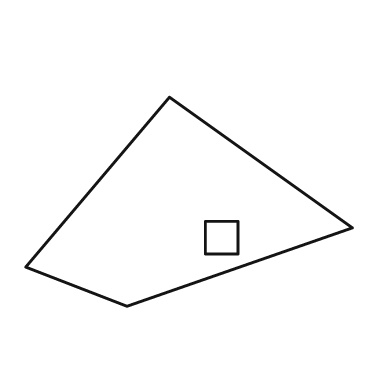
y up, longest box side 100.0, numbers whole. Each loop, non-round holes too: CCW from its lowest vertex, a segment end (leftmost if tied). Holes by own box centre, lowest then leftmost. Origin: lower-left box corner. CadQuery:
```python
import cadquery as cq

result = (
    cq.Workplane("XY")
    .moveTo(31.0, 0.0)
    .lineTo(100.0, 24.0)
    .lineTo(44.0, 64.0)
    .lineTo(0.0, 12.0)
    .close()
    .moveTo(55.0, 16.0)
    .lineTo(65.0, 16.0)
    .lineTo(65.0, 26.0)
    .lineTo(55.0, 26.0)
    .close()
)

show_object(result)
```